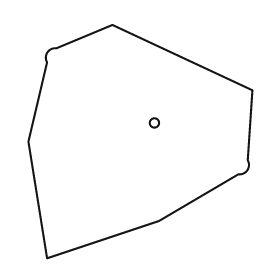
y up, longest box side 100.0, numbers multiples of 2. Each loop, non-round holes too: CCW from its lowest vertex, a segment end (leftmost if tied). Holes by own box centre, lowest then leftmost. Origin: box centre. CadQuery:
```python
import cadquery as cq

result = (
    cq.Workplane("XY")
    .moveTo(-40.0, -50.0)
    .lineTo(8.0, -34.0)
    .lineTo(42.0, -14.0)
    .threePointArc((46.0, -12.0), (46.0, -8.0))
    .lineTo(48.0, 22.0)
    .lineTo(-12.0, 50.0)
    .lineTo(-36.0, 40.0)
    .threePointArc((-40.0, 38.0), (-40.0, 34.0))
    .lineTo(-48.0, 0.0)
    .close()
    .moveTo(6.0, 8.0)
    .circle(2.0)
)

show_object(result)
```